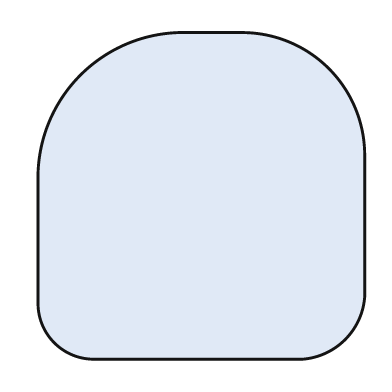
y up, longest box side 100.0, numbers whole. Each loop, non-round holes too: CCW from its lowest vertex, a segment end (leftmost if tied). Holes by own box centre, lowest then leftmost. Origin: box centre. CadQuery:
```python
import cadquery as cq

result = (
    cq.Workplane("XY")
    .moveTo(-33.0, -50.0)
    .lineTo(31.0, -50.0)
    .threePointArc((44.0, -44.0), (50.0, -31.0))
    .lineTo(50.0, 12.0)
    .threePointArc((39.0, 39.0), (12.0, 50.0))
    .lineTo(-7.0, 50.0)
    .threePointArc((-37.0, 37.0), (-50.0, 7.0))
    .lineTo(-50.0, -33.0)
    .threePointArc((-45.0, -45.0), (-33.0, -50.0))
    .close()
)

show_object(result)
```